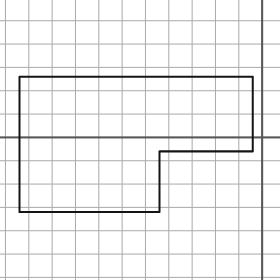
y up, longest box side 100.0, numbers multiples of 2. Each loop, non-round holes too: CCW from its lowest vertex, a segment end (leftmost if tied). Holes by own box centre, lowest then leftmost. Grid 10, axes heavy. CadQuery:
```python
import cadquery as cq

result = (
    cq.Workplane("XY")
    .moveTo(-104.0, -32.0)
    .lineTo(-44.0, -32.0)
    .lineTo(-44.0, -6.0)
    .lineTo(-4.0, -6.0)
    .lineTo(-4.0, 26.0)
    .lineTo(-104.0, 26.0)
    .close()
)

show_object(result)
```